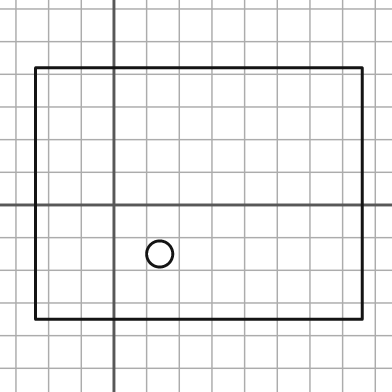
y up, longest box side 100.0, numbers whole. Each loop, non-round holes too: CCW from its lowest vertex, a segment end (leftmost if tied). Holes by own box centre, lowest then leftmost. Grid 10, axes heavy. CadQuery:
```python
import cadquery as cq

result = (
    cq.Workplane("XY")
    .moveTo(-24.0, -35.0)
    .lineTo(76.0, -35.0)
    .lineTo(76.0, 42.0)
    .lineTo(-24.0, 42.0)
    .close()
    .moveTo(14.0, -15.0)
    .circle(4.0)
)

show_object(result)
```